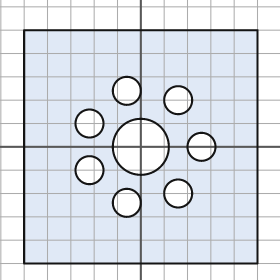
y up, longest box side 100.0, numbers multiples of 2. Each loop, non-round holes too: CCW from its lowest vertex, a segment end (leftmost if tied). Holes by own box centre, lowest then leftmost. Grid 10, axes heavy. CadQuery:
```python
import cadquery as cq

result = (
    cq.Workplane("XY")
    .moveTo(-50.0, -50.0)
    .lineTo(50.0, -50.0)
    .lineTo(50.0, 50.0)
    .lineTo(-50.0, 50.0)
    .close()
    .moveTo(-6.0, -24.0)
    .circle(6.0)
    .moveTo(16.0, -20.0)
    .circle(6.0)
    .moveTo(-22.0, -10.0)
    .circle(6.0)
    .moveTo(0.0, 0.0)
    .circle(12.0)
    .moveTo(26.0, 0.0)
    .circle(6.0)
    .moveTo(-22.0, 10.0)
    .circle(6.0)
    .moveTo(16.0, 20.0)
    .circle(6.0)
    .moveTo(-6.0, 24.0)
    .circle(6.0)
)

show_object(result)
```